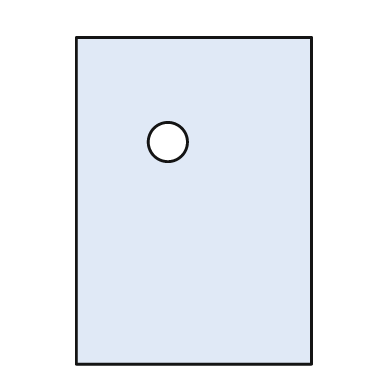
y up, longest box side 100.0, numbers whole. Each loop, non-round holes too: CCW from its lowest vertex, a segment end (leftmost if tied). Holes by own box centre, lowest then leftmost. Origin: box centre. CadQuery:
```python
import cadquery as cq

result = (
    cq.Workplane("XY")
    .moveTo(-36.0, -50.0)
    .lineTo(36.0, -50.0)
    .lineTo(36.0, 50.0)
    .lineTo(-36.0, 50.0)
    .close()
    .moveTo(-8.0, 18.0)
    .circle(6.0)
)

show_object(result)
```